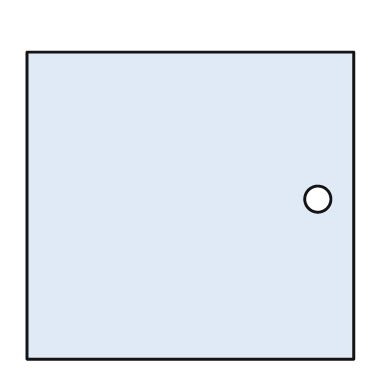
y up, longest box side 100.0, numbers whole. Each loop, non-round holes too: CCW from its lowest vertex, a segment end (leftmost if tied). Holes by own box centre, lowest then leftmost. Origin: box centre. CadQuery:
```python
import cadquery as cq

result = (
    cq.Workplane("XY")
    .moveTo(-50.0, -47.0)
    .lineTo(50.0, -47.0)
    .lineTo(50.0, 47.0)
    .lineTo(-50.0, 47.0)
    .close()
    .moveTo(39.0, 2.0)
    .circle(4.0)
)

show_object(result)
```